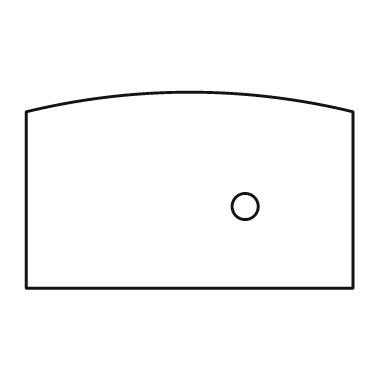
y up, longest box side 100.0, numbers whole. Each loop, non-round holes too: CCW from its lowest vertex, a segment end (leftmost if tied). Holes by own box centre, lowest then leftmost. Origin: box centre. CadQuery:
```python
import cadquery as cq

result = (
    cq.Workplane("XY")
    .moveTo(-50.0, -30.0)
    .lineTo(50.0, -30.0)
    .lineTo(50.0, 24.0)
    .threePointArc((0.0, 30.0), (-50.0, 24.0))
    .close()
    .moveTo(17.0, -5.0)
    .circle(4.0)
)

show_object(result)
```